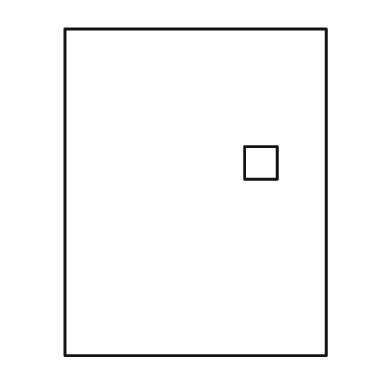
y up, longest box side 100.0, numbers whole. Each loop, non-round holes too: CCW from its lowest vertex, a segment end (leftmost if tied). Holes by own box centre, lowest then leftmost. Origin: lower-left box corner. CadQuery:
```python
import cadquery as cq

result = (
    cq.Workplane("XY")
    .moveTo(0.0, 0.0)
    .lineTo(80.0, 0.0)
    .lineTo(80.0, 100.0)
    .lineTo(0.0, 100.0)
    .close()
    .moveTo(55.0, 54.0)
    .lineTo(65.0, 54.0)
    .lineTo(65.0, 64.0)
    .lineTo(55.0, 64.0)
    .close()
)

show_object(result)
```